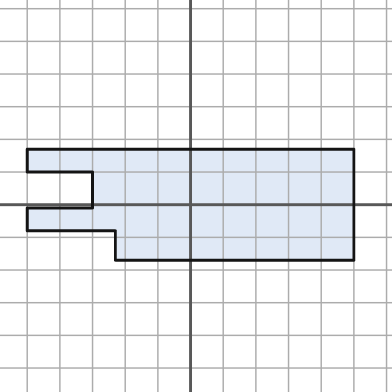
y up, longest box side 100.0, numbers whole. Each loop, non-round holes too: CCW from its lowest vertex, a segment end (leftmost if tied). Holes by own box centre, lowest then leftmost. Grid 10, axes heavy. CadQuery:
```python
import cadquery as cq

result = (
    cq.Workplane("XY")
    .moveTo(-23.0, -17.0)
    .lineTo(50.0, -17.0)
    .lineTo(50.0, 17.0)
    .lineTo(-50.0, 17.0)
    .lineTo(-50.0, 10.0)
    .lineTo(-30.0, 10.0)
    .lineTo(-30.0, -1.0)
    .lineTo(-50.0, -1.0)
    .lineTo(-50.0, -8.0)
    .lineTo(-23.0, -8.0)
    .close()
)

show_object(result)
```